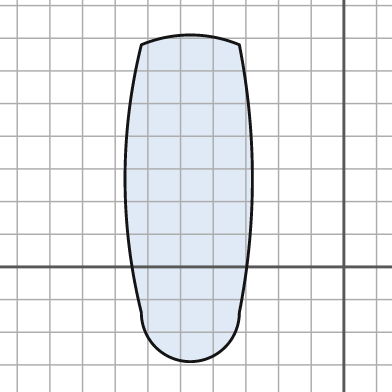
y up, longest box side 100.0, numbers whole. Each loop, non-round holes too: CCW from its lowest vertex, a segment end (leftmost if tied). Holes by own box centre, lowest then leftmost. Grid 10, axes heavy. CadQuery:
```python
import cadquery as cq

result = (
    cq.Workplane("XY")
    .moveTo(-62.0, -14.0)
    .threePointArc((-47.0, -29.0), (-32.0, -14.0))
    .threePointArc((-28.0, 27.0), (-32.0, 68.0))
    .threePointArc((-47.0, 71.0), (-62.0, 68.0))
    .threePointArc((-67.0, 27.0), (-62.0, -14.0))
    .close()
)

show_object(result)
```